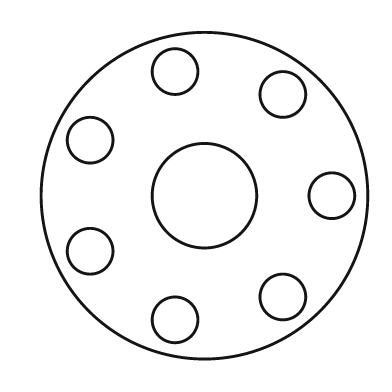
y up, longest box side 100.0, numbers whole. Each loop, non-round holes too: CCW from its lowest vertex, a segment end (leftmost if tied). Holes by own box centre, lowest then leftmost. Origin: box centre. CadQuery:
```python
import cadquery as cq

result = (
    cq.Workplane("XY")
    .moveTo(0.0, 0.0)
    .circle(50.0)
    .moveTo(-9.0, -38.0)
    .circle(7.0)
    .moveTo(24.0, -31.0)
    .circle(7.0)
    .moveTo(-35.0, -17.0)
    .circle(7.0)
    .moveTo(0.0, 0.0)
    .circle(16.0)
    .moveTo(39.0, 0.0)
    .circle(7.0)
    .moveTo(-35.0, 17.0)
    .circle(7.0)
    .moveTo(24.0, 31.0)
    .circle(7.0)
    .moveTo(-9.0, 38.0)
    .circle(7.0)
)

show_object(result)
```